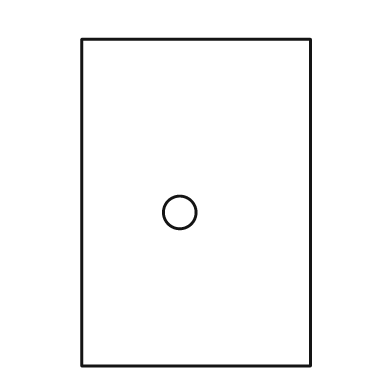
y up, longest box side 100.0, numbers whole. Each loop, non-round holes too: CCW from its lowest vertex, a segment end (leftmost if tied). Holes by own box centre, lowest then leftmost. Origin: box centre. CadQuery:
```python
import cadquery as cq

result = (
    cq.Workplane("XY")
    .moveTo(-35.0, -50.0)
    .lineTo(35.0, -50.0)
    .lineTo(35.0, 50.0)
    .lineTo(-35.0, 50.0)
    .close()
    .moveTo(-5.0, -3.0)
    .circle(5.0)
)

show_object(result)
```